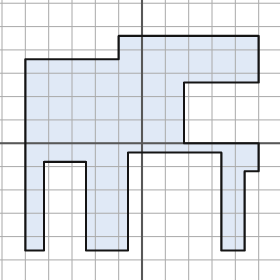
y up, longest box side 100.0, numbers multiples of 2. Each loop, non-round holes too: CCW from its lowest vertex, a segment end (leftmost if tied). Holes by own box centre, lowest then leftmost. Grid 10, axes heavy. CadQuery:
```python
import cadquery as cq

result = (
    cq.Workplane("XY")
    .moveTo(-50.0, -46.0)
    .lineTo(-42.0, -46.0)
    .lineTo(-42.0, -8.0)
    .lineTo(-24.0, -8.0)
    .lineTo(-24.0, -46.0)
    .lineTo(-6.0, -46.0)
    .lineTo(-6.0, -4.0)
    .lineTo(34.0, -4.0)
    .lineTo(34.0, -46.0)
    .lineTo(44.0, -46.0)
    .lineTo(44.0, -12.0)
    .lineTo(50.0, -12.0)
    .lineTo(50.0, 0.0)
    .lineTo(18.0, 0.0)
    .lineTo(18.0, 26.0)
    .lineTo(50.0, 26.0)
    .lineTo(50.0, 46.0)
    .lineTo(-10.0, 46.0)
    .lineTo(-10.0, 36.0)
    .lineTo(-50.0, 36.0)
    .close()
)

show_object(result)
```